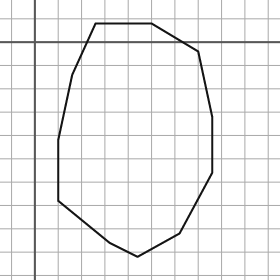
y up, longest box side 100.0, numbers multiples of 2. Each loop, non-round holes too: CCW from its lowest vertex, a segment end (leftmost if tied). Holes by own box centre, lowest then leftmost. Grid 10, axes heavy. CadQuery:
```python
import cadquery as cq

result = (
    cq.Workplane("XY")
    .moveTo(44.0, -92.0)
    .lineTo(62.0, -82.0)
    .lineTo(76.0, -56.0)
    .lineTo(76.0, -32.0)
    .lineTo(70.0, -4.0)
    .lineTo(50.0, 8.0)
    .lineTo(26.0, 8.0)
    .lineTo(16.0, -14.0)
    .lineTo(10.0, -42.0)
    .lineTo(10.0, -68.0)
    .lineTo(32.0, -86.0)
    .close()
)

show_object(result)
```